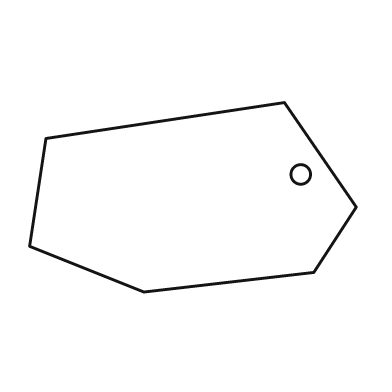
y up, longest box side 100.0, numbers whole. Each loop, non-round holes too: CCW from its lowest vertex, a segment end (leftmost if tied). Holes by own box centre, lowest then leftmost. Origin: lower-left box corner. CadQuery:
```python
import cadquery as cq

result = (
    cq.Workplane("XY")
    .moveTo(35.0, 0.0)
    .lineTo(87.0, 6.0)
    .lineTo(100.0, 26.0)
    .lineTo(78.0, 58.0)
    .lineTo(5.0, 47.0)
    .lineTo(0.0, 14.0)
    .close()
    .moveTo(83.0, 36.0)
    .circle(3.0)
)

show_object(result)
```